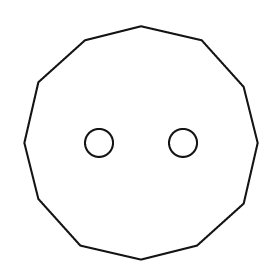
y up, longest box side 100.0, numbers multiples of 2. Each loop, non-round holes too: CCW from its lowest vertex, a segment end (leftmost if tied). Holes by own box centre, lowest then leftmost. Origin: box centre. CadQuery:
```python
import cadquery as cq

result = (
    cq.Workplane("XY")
    .moveTo(0.0, -50.0)
    .lineTo(24.0, -44.0)
    .lineTo(44.0, -26.0)
    .lineTo(50.0, 0.0)
    .lineTo(44.0, 24.0)
    .lineTo(26.0, 44.0)
    .lineTo(0.0, 50.0)
    .lineTo(-24.0, 44.0)
    .lineTo(-44.0, 26.0)
    .lineTo(-50.0, 0.0)
    .lineTo(-44.0, -24.0)
    .lineTo(-26.0, -44.0)
    .close()
    .moveTo(-18.0, 0.0)
    .circle(6.0)
    .moveTo(18.0, 0.0)
    .circle(6.0)
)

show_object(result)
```